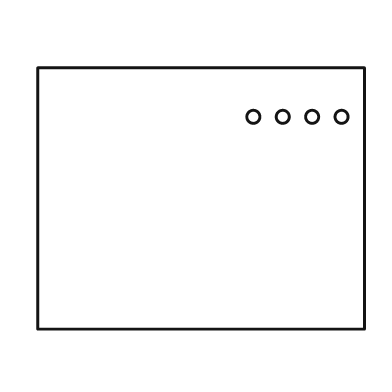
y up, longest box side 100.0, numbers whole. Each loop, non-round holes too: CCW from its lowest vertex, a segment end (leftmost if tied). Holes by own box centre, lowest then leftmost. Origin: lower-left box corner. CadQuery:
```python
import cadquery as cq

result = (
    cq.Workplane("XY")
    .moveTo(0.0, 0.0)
    .lineTo(100.0, 0.0)
    .lineTo(100.0, 80.0)
    .lineTo(0.0, 80.0)
    .close()
    .moveTo(66.0, 65.0)
    .circle(2.0)
    .moveTo(75.0, 65.0)
    .circle(2.0)
    .moveTo(84.0, 65.0)
    .circle(2.0)
    .moveTo(93.0, 65.0)
    .circle(2.0)
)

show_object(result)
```